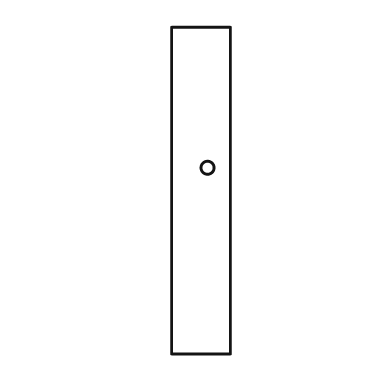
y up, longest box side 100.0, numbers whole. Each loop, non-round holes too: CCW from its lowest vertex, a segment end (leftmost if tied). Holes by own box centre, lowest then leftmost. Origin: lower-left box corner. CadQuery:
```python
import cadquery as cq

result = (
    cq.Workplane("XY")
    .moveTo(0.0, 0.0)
    .lineTo(18.0, 0.0)
    .lineTo(18.0, 100.0)
    .lineTo(0.0, 100.0)
    .close()
    .moveTo(11.0, 57.0)
    .circle(2.0)
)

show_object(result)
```